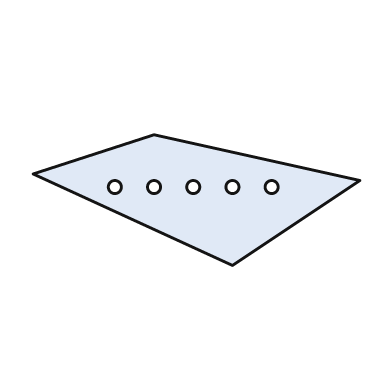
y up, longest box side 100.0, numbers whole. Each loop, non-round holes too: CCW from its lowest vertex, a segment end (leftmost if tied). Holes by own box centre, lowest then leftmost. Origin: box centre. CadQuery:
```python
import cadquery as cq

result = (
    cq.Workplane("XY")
    .moveTo(11.0, -20.0)
    .lineTo(50.0, 6.0)
    .lineTo(-13.0, 20.0)
    .lineTo(-50.0, 8.0)
    .close()
    .moveTo(-25.0, 4.0)
    .circle(2.0)
    .moveTo(-13.0, 4.0)
    .circle(2.0)
    .moveTo(-1.0, 4.0)
    .circle(2.0)
    .moveTo(11.0, 4.0)
    .circle(2.0)
    .moveTo(23.0, 4.0)
    .circle(2.0)
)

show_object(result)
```